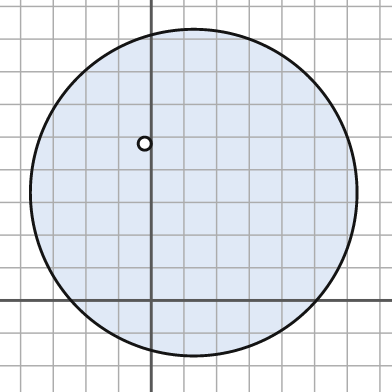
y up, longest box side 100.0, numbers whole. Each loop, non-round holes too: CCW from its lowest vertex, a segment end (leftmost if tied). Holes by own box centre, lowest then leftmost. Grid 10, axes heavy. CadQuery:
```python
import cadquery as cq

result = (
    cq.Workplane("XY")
    .moveTo(13.0, 33.0)
    .circle(50.0)
    .moveTo(-2.0, 48.0)
    .circle(2.0)
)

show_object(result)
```